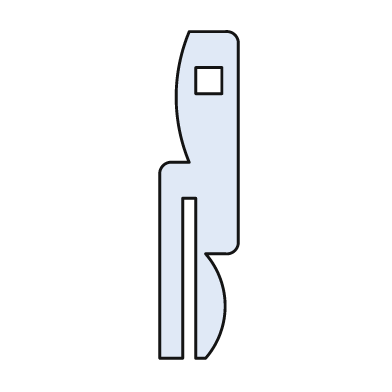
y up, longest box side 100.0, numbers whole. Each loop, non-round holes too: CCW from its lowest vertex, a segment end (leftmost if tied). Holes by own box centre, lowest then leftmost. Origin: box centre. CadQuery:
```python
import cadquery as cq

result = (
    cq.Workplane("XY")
    .moveTo(-12.0, -50.0)
    .lineTo(-5.0, -50.0)
    .lineTo(-5.0, -1.0)
    .lineTo(-1.0, -1.0)
    .lineTo(-1.0, -50.0)
    .lineTo(2.0, -50.0)
    .threePointArc((8.0, -34.0), (2.0, -18.0))
    .lineTo(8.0, -18.0)
    .threePointArc((11.0, -17.0), (12.0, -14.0))
    .lineTo(12.0, 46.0)
    .threePointArc((11.0, 49.0), (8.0, 50.0))
    .lineTo(-3.0, 50.0)
    .threePointArc((-7.0, 30.0), (-3.0, 10.0))
    .lineTo(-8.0, 10.0)
    .threePointArc((-11.0, 9.0), (-12.0, 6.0))
    .close()
    .moveTo(-1.0, 31.0)
    .lineTo(7.0, 31.0)
    .lineTo(7.0, 39.0)
    .lineTo(-1.0, 39.0)
    .close()
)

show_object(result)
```